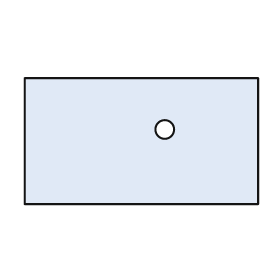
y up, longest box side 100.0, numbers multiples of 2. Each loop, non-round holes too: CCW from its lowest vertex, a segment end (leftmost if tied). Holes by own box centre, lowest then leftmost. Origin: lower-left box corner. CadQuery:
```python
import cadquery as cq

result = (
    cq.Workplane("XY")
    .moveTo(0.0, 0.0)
    .lineTo(100.0, 0.0)
    .lineTo(100.0, 54.0)
    .lineTo(0.0, 54.0)
    .close()
    .moveTo(60.0, 32.0)
    .circle(4.0)
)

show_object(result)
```